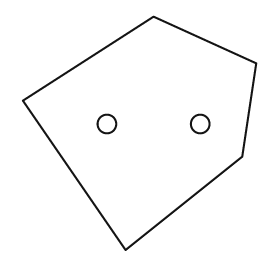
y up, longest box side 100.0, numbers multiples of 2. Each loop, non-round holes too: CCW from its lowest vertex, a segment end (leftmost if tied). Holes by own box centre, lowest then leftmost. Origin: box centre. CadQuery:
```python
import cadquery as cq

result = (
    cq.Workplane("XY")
    .moveTo(-6.0, -50.0)
    .lineTo(44.0, -10.0)
    .lineTo(50.0, 30.0)
    .lineTo(6.0, 50.0)
    .lineTo(-50.0, 14.0)
    .close()
    .moveTo(-14.0, 4.0)
    .circle(4.0)
    .moveTo(26.0, 4.0)
    .circle(4.0)
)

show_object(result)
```